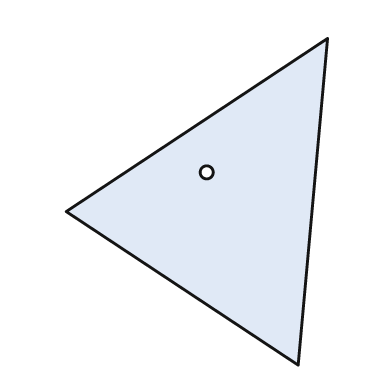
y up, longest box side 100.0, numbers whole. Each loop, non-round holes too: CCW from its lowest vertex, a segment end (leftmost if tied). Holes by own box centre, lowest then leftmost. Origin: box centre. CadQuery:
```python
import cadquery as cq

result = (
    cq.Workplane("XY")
    .moveTo(31.0, -50.0)
    .lineTo(40.0, 50.0)
    .lineTo(-40.0, -3.0)
    .close()
    .moveTo(3.0, 9.0)
    .circle(2.0)
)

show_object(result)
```